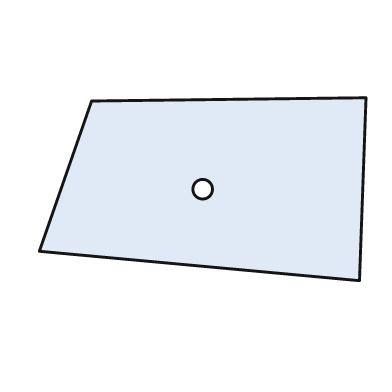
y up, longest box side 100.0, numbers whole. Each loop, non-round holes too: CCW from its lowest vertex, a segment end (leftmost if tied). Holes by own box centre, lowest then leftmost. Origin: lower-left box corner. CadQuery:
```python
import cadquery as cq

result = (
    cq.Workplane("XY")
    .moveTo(98.0, 0.0)
    .lineTo(100.0, 56.0)
    .lineTo(16.0, 55.0)
    .lineTo(0.0, 9.0)
    .close()
    .moveTo(50.0, 28.0)
    .circle(3.0)
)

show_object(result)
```